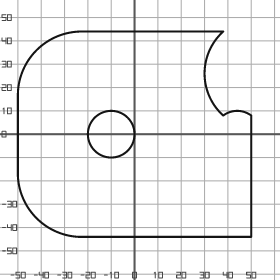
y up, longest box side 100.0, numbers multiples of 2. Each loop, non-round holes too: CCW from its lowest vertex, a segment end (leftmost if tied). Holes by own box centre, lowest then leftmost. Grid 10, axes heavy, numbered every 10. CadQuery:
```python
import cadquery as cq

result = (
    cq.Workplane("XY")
    .moveTo(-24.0, -44.0)
    .lineTo(50.0, -44.0)
    .lineTo(50.0, 8.0)
    .threePointArc((44.0, 10.0), (38.0, 8.0))
    .threePointArc((30.0, 26.0), (38.0, 44.0))
    .lineTo(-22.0, 44.0)
    .threePointArc((-42.0, 36.0), (-50.0, 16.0))
    .lineTo(-50.0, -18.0)
    .threePointArc((-42.0, -36.0), (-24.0, -44.0))
    .close()
    .moveTo(-10.0, 0.0)
    .circle(10.0)
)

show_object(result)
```